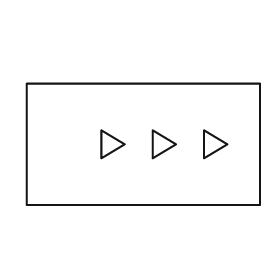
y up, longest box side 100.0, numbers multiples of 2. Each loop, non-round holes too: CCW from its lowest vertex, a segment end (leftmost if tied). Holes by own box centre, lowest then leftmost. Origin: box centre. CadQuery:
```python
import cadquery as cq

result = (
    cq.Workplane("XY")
    .moveTo(-50.0, -26.0)
    .lineTo(50.0, -26.0)
    .lineTo(50.0, 26.0)
    .lineTo(-50.0, 26.0)
    .close()
    .moveTo(-18.0, -6.0)
    .lineTo(-8.0, 0.0)
    .lineTo(-18.0, 6.0)
    .close()
    .moveTo(4.0, -6.0)
    .lineTo(14.0, 0.0)
    .lineTo(4.0, 6.0)
    .close()
    .moveTo(26.0, -6.0)
    .lineTo(36.0, 0.0)
    .lineTo(26.0, 6.0)
    .close()
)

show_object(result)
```